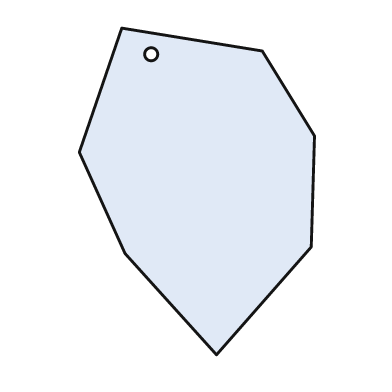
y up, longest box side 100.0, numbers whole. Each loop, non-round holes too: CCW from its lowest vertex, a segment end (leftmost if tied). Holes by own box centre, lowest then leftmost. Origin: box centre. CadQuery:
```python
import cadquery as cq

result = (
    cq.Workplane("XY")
    .moveTo(6.0, -50.0)
    .lineTo(35.0, -17.0)
    .lineTo(36.0, 17.0)
    .lineTo(20.0, 43.0)
    .lineTo(-23.0, 50.0)
    .lineTo(-36.0, 12.0)
    .lineTo(-22.0, -19.0)
    .close()
    .moveTo(-14.0, 42.0)
    .circle(2.0)
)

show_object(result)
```